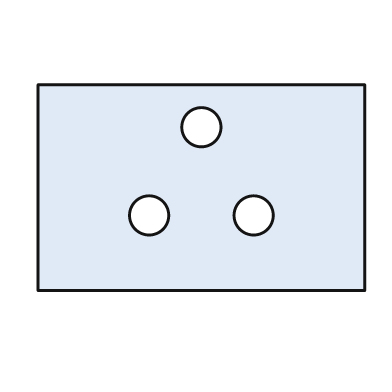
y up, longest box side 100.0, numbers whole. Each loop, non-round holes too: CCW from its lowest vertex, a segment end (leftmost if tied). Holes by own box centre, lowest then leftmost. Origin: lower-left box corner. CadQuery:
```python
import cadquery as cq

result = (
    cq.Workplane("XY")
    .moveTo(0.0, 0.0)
    .lineTo(100.0, 0.0)
    .lineTo(100.0, 63.0)
    .lineTo(0.0, 63.0)
    .close()
    .moveTo(34.0, 23.0)
    .circle(6.0)
    .moveTo(66.0, 23.0)
    .circle(6.0)
    .moveTo(50.0, 50.0)
    .circle(6.0)
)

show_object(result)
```